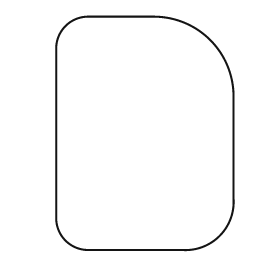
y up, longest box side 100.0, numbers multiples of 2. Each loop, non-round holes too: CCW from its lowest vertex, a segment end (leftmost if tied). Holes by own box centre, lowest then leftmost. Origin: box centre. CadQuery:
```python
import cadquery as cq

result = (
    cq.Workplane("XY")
    .moveTo(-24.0, -50.0)
    .lineTo(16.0, -50.0)
    .threePointArc((32.0, -44.0), (38.0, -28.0))
    .lineTo(38.0, 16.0)
    .threePointArc((28.0, 40.0), (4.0, 50.0))
    .lineTo(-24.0, 50.0)
    .threePointArc((-34.0, 46.0), (-38.0, 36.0))
    .lineTo(-38.0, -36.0)
    .threePointArc((-34.0, -46.0), (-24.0, -50.0))
    .close()
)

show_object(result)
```